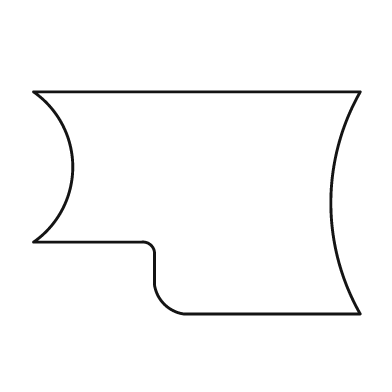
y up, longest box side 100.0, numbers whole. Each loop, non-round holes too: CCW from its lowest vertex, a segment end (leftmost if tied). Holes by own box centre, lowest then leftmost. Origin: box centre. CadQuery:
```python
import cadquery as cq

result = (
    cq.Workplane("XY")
    .moveTo(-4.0, -34.0)
    .lineTo(50.0, -34.0)
    .threePointArc((41.0, 0.0), (50.0, 34.0))
    .lineTo(-50.0, 34.0)
    .threePointArc((-38.0, 11.0), (-50.0, -12.0))
    .lineTo(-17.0, -12.0)
    .threePointArc((-14.0, -13.0), (-13.0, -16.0))
    .lineTo(-13.0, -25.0)
    .threePointArc((-10.0, -31.0), (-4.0, -34.0))
    .close()
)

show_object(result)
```